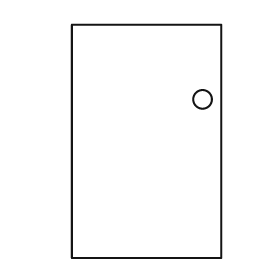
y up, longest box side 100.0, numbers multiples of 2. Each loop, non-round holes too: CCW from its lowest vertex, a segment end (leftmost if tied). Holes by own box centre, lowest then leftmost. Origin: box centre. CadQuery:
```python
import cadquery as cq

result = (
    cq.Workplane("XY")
    .moveTo(-32.0, -50.0)
    .lineTo(32.0, -50.0)
    .lineTo(32.0, 50.0)
    .lineTo(-32.0, 50.0)
    .close()
    .moveTo(24.0, 18.0)
    .circle(4.0)
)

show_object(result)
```